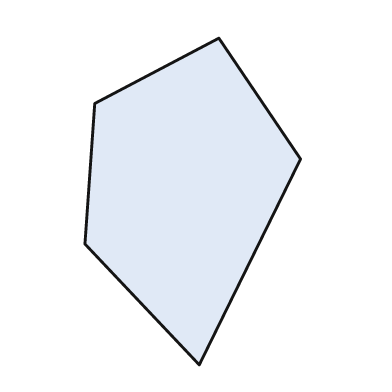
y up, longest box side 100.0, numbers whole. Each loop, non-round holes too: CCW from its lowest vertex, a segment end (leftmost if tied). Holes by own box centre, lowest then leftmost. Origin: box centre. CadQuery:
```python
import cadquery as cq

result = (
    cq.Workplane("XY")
    .moveTo(2.0, -50.0)
    .lineTo(33.0, 13.0)
    .lineTo(8.0, 50.0)
    .lineTo(-30.0, 30.0)
    .lineTo(-33.0, -13.0)
    .close()
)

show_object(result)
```